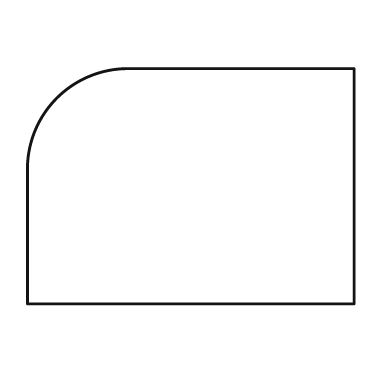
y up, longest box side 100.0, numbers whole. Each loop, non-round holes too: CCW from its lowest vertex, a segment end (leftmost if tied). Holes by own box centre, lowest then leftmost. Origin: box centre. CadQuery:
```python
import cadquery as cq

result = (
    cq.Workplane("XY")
    .moveTo(-50.0, -36.0)
    .lineTo(50.0, -36.0)
    .lineTo(50.0, 36.0)
    .lineTo(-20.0, 36.0)
    .threePointArc((-41.0, 27.0), (-50.0, 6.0))
    .close()
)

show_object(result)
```